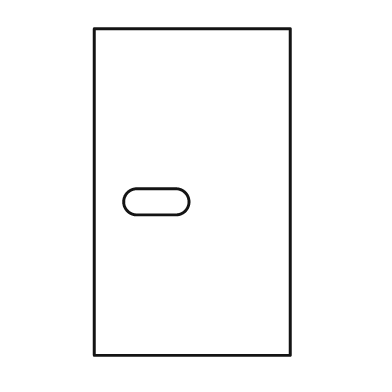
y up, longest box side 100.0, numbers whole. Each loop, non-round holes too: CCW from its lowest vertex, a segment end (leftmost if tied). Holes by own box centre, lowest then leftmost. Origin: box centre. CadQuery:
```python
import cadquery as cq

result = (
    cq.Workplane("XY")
    .moveTo(-30.0, -50.0)
    .lineTo(30.0, -50.0)
    .lineTo(30.0, 50.0)
    .lineTo(-30.0, 50.0)
    .close()
    .moveTo(-17.0, -7.0)
    .lineTo(-5.0, -7.0)
    .threePointArc((-1.0, -3.0), (-5.0, 1.0))
    .lineTo(-17.0, 1.0)
    .threePointArc((-21.0, -3.0), (-17.0, -7.0))
    .close()
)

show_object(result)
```